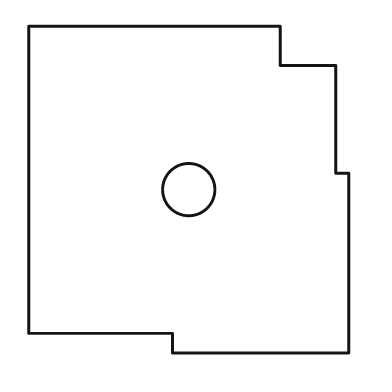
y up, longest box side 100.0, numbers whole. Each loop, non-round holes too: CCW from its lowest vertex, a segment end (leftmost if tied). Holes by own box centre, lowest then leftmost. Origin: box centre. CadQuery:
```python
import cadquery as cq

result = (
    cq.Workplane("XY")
    .moveTo(-5.0, -50.0)
    .lineTo(49.0, -50.0)
    .lineTo(49.0, 5.0)
    .lineTo(45.0, 5.0)
    .lineTo(45.0, 38.0)
    .lineTo(28.0, 38.0)
    .lineTo(28.0, 50.0)
    .lineTo(-49.0, 50.0)
    .lineTo(-49.0, -44.0)
    .lineTo(-5.0, -44.0)
    .close()
    .moveTo(0.0, 0.0)
    .circle(8.0)
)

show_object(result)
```